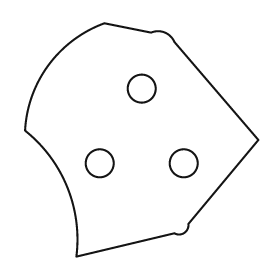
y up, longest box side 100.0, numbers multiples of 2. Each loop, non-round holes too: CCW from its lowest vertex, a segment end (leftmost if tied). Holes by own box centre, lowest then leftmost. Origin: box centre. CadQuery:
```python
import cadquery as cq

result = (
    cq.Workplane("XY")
    .moveTo(-28.0, -50.0)
    .lineTo(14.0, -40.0)
    .threePointArc((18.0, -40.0), (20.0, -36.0))
    .lineTo(50.0, 0.0)
    .lineTo(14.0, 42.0)
    .threePointArc((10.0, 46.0), (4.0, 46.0))
    .lineTo(-16.0, 50.0)
    .threePointArc((-40.0, 32.0), (-50.0, 4.0))
    .threePointArc((-32.0, -20.0), (-28.0, -50.0))
    .close()
    .moveTo(-18.0, -10.0)
    .circle(6.0)
    .moveTo(18.0, -10.0)
    .circle(6.0)
    .moveTo(0.0, 22.0)
    .circle(6.0)
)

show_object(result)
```